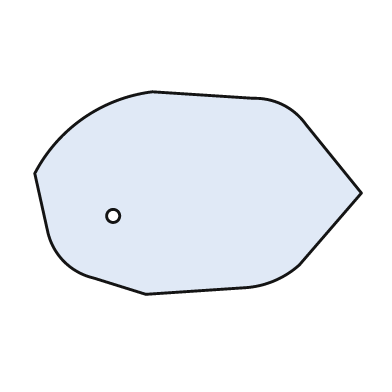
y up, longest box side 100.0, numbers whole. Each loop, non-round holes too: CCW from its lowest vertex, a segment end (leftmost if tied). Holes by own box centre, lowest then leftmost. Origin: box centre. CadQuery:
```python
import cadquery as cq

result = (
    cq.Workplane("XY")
    .moveTo(-16.0, -31.0)
    .lineTo(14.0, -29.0)
    .threePointArc((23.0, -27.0), (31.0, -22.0))
    .lineTo(50.0, 0.0)
    .lineTo(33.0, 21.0)
    .threePointArc((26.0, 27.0), (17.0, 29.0))
    .lineTo(-14.0, 31.0)
    .threePointArc((-35.0, 23.0), (-50.0, 6.0))
    .lineTo(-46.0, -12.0)
    .threePointArc((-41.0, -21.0), (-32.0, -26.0))
    .close()
    .moveTo(-26.0, -7.0)
    .circle(2.0)
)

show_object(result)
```